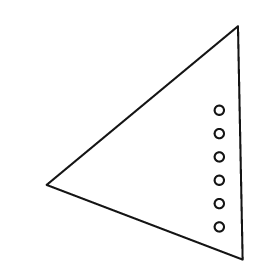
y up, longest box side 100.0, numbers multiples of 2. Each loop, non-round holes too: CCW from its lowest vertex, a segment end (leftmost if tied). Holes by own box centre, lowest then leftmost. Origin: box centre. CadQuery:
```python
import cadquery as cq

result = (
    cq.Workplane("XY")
    .moveTo(42.0, -50.0)
    .lineTo(40.0, 50.0)
    .lineTo(-42.0, -18.0)
    .close()
    .moveTo(32.0, -36.0)
    .circle(2.0)
    .moveTo(32.0, -26.0)
    .circle(2.0)
    .moveTo(32.0, -16.0)
    .circle(2.0)
    .moveTo(32.0, -6.0)
    .circle(2.0)
    .moveTo(32.0, 4.0)
    .circle(2.0)
    .moveTo(32.0, 14.0)
    .circle(2.0)
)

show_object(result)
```